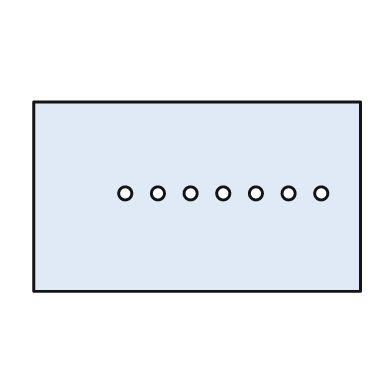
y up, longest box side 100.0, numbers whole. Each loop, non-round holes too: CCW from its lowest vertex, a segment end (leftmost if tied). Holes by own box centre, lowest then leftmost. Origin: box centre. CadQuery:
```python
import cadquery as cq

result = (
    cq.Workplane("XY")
    .moveTo(-50.0, -29.0)
    .lineTo(50.0, -29.0)
    .lineTo(50.0, 29.0)
    .lineTo(-50.0, 29.0)
    .close()
    .moveTo(-22.0, 1.0)
    .circle(2.0)
    .moveTo(-12.0, 1.0)
    .circle(2.0)
    .moveTo(-2.0, 1.0)
    .circle(2.0)
    .moveTo(8.0, 1.0)
    .circle(2.0)
    .moveTo(18.0, 1.0)
    .circle(2.0)
    .moveTo(28.0, 1.0)
    .circle(2.0)
    .moveTo(38.0, 1.0)
    .circle(2.0)
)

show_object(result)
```